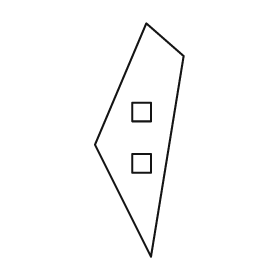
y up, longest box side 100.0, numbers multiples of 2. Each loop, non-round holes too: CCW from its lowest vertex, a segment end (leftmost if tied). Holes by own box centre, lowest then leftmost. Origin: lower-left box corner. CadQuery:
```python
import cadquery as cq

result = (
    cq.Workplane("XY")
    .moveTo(24.0, 0.0)
    .lineTo(38.0, 86.0)
    .lineTo(22.0, 100.0)
    .lineTo(0.0, 48.0)
    .close()
    .moveTo(16.0, 36.0)
    .lineTo(24.0, 36.0)
    .lineTo(24.0, 44.0)
    .lineTo(16.0, 44.0)
    .close()
    .moveTo(16.0, 58.0)
    .lineTo(24.0, 58.0)
    .lineTo(24.0, 66.0)
    .lineTo(16.0, 66.0)
    .close()
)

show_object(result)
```